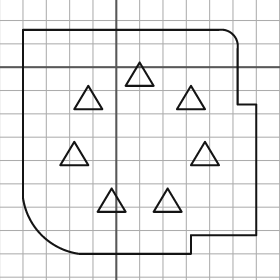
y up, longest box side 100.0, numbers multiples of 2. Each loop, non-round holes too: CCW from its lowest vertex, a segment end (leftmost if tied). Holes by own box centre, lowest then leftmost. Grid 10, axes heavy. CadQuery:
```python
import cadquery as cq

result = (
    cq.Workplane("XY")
    .moveTo(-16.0, -80.0)
    .lineTo(32.0, -80.0)
    .lineTo(32.0, -72.0)
    .lineTo(60.0, -72.0)
    .lineTo(60.0, -16.0)
    .lineTo(52.0, -16.0)
    .lineTo(52.0, 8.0)
    .threePointArc((50.0, 14.0), (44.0, 16.0))
    .lineTo(-40.0, 16.0)
    .lineTo(-40.0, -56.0)
    .threePointArc((-32.0, -72.0), (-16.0, -80.0))
    .close()
    .moveTo(-8.0, -62.0)
    .lineTo(4.0, -62.0)
    .lineTo(-2.0, -52.0)
    .close()
    .moveTo(16.0, -62.0)
    .lineTo(28.0, -62.0)
    .lineTo(22.0, -52.0)
    .close()
    .moveTo(-24.0, -42.0)
    .lineTo(-12.0, -42.0)
    .lineTo(-18.0, -32.0)
    .close()
    .moveTo(32.0, -42.0)
    .lineTo(44.0, -42.0)
    .lineTo(38.0, -32.0)
    .close()
    .moveTo(-18.0, -18.0)
    .lineTo(-6.0, -18.0)
    .lineTo(-12.0, -8.0)
    .close()
    .moveTo(26.0, -18.0)
    .lineTo(38.0, -18.0)
    .lineTo(32.0, -8.0)
    .close()
    .moveTo(4.0, -8.0)
    .lineTo(16.0, -8.0)
    .lineTo(10.0, 2.0)
    .close()
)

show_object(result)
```